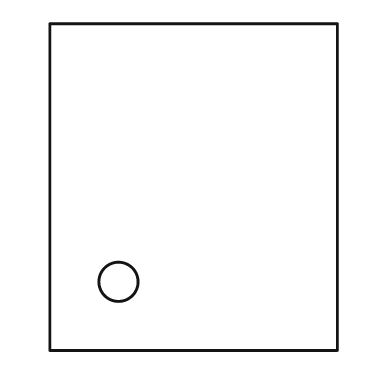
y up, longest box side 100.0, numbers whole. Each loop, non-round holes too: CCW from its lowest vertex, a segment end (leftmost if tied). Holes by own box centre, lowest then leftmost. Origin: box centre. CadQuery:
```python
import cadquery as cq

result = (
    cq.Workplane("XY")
    .moveTo(-44.0, -50.0)
    .lineTo(44.0, -50.0)
    .lineTo(44.0, 50.0)
    .lineTo(-44.0, 50.0)
    .close()
    .moveTo(-23.0, -29.0)
    .circle(6.0)
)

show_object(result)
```